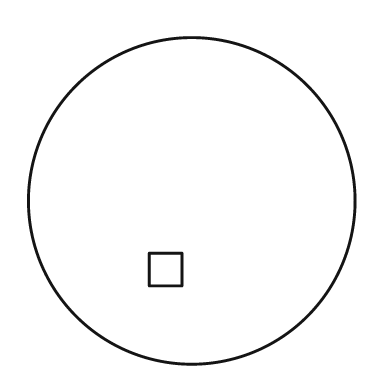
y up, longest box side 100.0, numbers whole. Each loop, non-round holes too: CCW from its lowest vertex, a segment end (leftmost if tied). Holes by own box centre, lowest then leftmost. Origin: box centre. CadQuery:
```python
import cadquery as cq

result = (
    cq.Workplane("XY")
    .moveTo(0.0, 0.0)
    .circle(50.0)
    .moveTo(-13.0, -26.0)
    .lineTo(-3.0, -26.0)
    .lineTo(-3.0, -16.0)
    .lineTo(-13.0, -16.0)
    .close()
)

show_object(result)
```